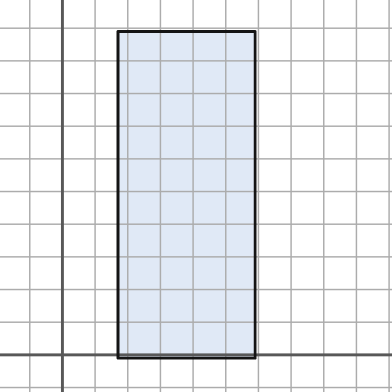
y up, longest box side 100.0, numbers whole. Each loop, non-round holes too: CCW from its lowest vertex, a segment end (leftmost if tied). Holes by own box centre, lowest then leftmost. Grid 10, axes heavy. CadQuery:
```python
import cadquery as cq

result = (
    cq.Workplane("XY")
    .moveTo(17.0, -1.0)
    .lineTo(59.0, -1.0)
    .lineTo(59.0, 99.0)
    .lineTo(17.0, 99.0)
    .close()
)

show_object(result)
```